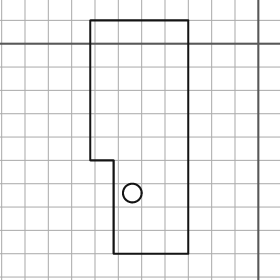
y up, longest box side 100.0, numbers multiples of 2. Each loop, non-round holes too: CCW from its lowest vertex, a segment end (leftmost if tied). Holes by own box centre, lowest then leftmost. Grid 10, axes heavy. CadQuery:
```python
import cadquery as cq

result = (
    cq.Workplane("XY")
    .moveTo(-62.0, -90.0)
    .lineTo(-30.0, -90.0)
    .lineTo(-30.0, 10.0)
    .lineTo(-72.0, 10.0)
    .lineTo(-72.0, -50.0)
    .lineTo(-62.0, -50.0)
    .close()
    .moveTo(-54.0, -64.0)
    .circle(4.0)
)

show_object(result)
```